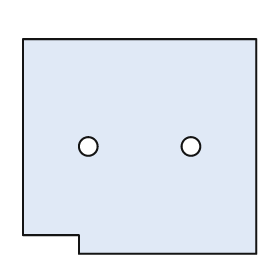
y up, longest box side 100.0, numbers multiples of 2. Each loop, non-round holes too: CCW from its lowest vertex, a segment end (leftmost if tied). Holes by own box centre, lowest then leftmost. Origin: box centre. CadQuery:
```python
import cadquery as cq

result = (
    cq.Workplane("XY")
    .moveTo(-26.0, -46.0)
    .lineTo(50.0, -46.0)
    .lineTo(50.0, 46.0)
    .lineTo(-50.0, 46.0)
    .lineTo(-50.0, -38.0)
    .lineTo(-26.0, -38.0)
    .close()
    .moveTo(-22.0, 0.0)
    .circle(4.0)
    .moveTo(22.0, 0.0)
    .circle(4.0)
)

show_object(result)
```